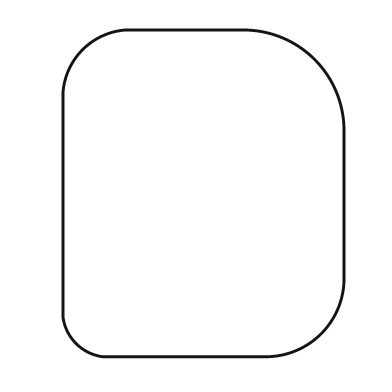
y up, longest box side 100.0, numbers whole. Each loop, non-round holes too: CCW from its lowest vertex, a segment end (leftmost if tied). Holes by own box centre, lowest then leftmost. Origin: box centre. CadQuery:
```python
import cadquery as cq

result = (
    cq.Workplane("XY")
    .moveTo(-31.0, -50.0)
    .lineTo(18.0, -50.0)
    .threePointArc((36.0, -43.0), (43.0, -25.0))
    .lineTo(43.0, 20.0)
    .threePointArc((34.0, 41.0), (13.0, 50.0))
    .lineTo(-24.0, 50.0)
    .threePointArc((-37.0, 44.0), (-43.0, 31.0))
    .lineTo(-43.0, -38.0)
    .threePointArc((-39.0, -46.0), (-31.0, -50.0))
    .close()
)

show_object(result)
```